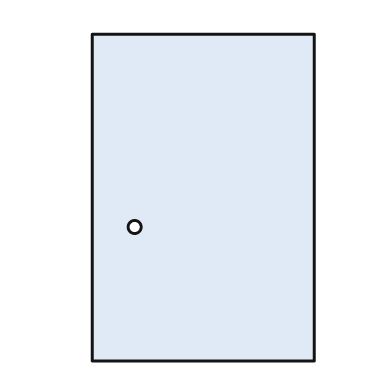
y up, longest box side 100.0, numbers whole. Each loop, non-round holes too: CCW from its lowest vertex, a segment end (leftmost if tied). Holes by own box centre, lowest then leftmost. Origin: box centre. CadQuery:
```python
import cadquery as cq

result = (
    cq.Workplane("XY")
    .moveTo(-34.0, -50.0)
    .lineTo(34.0, -50.0)
    .lineTo(34.0, 50.0)
    .lineTo(-34.0, 50.0)
    .close()
    .moveTo(-21.0, -9.0)
    .circle(2.0)
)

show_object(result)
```